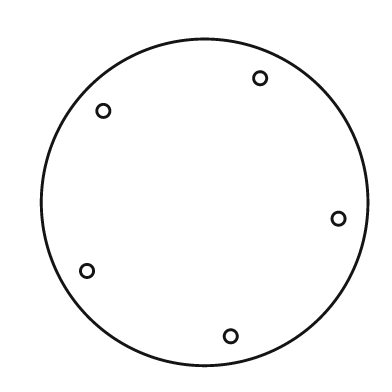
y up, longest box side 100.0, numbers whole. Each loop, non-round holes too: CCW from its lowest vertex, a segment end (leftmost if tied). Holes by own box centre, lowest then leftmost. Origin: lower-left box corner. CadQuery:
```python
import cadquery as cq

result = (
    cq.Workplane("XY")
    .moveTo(50.0, 50.0)
    .circle(50.0)
    .moveTo(58.0, 9.0)
    .circle(2.0)
    .moveTo(14.0, 29.0)
    .circle(2.0)
    .moveTo(91.0, 45.0)
    .circle(2.0)
    .moveTo(19.0, 78.0)
    .circle(2.0)
    .moveTo(67.0, 88.0)
    .circle(2.0)
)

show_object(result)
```